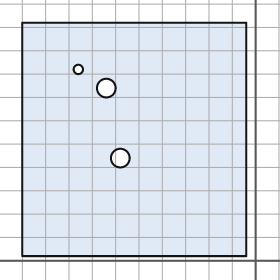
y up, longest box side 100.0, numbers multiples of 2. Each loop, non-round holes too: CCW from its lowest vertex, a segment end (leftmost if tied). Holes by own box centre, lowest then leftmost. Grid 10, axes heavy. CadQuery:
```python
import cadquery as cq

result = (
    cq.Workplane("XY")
    .moveTo(-100.0, 2.0)
    .lineTo(-4.0, 2.0)
    .lineTo(-4.0, 102.0)
    .lineTo(-100.0, 102.0)
    .close()
    .moveTo(-58.0, 44.0)
    .circle(4.0)
    .moveTo(-64.0, 74.0)
    .circle(4.0)
    .moveTo(-76.0, 82.0)
    .circle(2.0)
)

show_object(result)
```